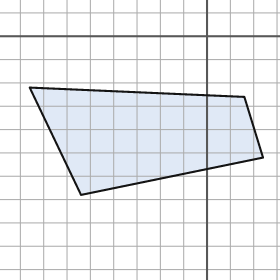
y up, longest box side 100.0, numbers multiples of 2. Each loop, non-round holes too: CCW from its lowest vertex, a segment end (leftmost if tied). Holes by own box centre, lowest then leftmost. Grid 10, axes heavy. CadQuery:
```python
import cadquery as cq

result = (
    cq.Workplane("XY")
    .moveTo(-54.0, -68.0)
    .lineTo(24.0, -52.0)
    .lineTo(16.0, -26.0)
    .lineTo(-76.0, -22.0)
    .close()
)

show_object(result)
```